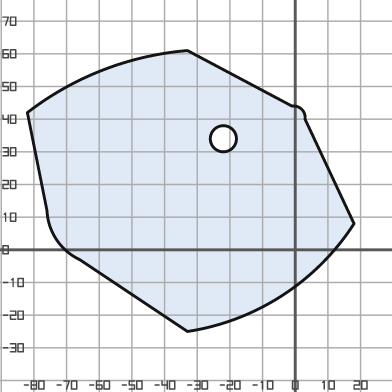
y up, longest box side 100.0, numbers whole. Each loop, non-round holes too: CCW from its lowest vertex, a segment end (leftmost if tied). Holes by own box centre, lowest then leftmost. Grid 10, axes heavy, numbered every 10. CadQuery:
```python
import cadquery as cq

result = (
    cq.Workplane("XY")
    .moveTo(-33.0, -25.0)
    .threePointArc((-4.0, -14.0), (18.0, 8.0))
    .lineTo(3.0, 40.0)
    .threePointArc((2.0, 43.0), (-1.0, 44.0))
    .lineTo(-33.0, 61.0)
    .threePointArc((-59.0, 55.0), (-82.0, 42.0))
    .lineTo(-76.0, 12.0)
    .threePointArc((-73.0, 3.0), (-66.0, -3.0))
    .close()
    .moveTo(-22.0, 34.0)
    .circle(4.0)
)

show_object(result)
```